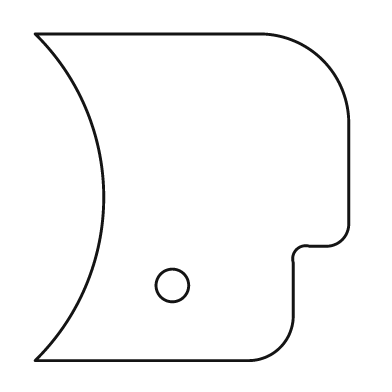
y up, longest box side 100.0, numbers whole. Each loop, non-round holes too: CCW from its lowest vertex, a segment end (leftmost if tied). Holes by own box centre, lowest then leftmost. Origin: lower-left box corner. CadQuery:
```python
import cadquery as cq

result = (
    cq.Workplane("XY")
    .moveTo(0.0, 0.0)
    .lineTo(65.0, 0.0)
    .threePointArc((75.0, 4.0), (79.0, 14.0))
    .lineTo(79.0, 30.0)
    .threePointArc((80.0, 34.0), (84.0, 35.0))
    .lineTo(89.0, 35.0)
    .threePointArc((94.0, 37.0), (96.0, 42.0))
    .lineTo(96.0, 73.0)
    .threePointArc((88.0, 92.0), (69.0, 100.0))
    .lineTo(0.0, 100.0)
    .threePointArc((21.0, 50.0), (0.0, 0.0))
    .close()
    .moveTo(42.0, 23.0)
    .circle(5.0)
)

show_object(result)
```